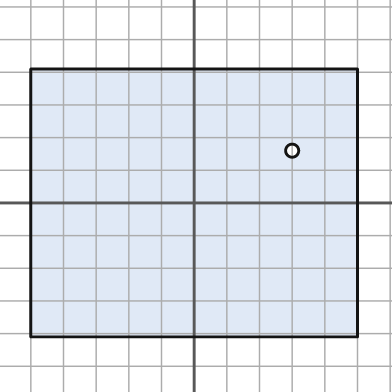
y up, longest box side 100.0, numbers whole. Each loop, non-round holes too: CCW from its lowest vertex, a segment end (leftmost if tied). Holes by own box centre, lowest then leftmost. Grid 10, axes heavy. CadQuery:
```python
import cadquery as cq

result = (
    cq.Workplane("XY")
    .moveTo(-50.0, -41.0)
    .lineTo(50.0, -41.0)
    .lineTo(50.0, 41.0)
    .lineTo(-50.0, 41.0)
    .close()
    .moveTo(30.0, 16.0)
    .circle(2.0)
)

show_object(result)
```